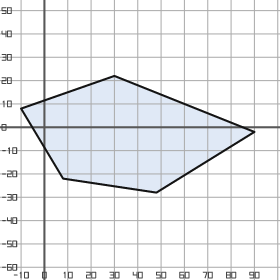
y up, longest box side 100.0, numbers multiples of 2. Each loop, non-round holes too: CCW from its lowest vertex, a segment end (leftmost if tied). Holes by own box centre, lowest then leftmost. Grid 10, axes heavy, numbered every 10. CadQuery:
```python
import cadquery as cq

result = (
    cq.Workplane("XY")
    .moveTo(48.0, -28.0)
    .lineTo(90.0, -2.0)
    .lineTo(30.0, 22.0)
    .lineTo(-10.0, 8.0)
    .lineTo(8.0, -22.0)
    .close()
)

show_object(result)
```